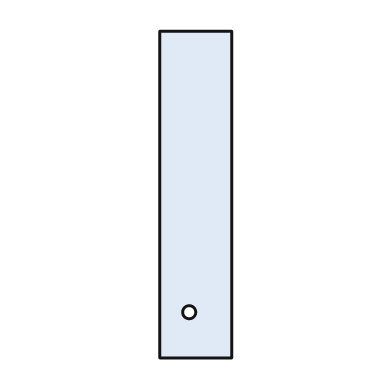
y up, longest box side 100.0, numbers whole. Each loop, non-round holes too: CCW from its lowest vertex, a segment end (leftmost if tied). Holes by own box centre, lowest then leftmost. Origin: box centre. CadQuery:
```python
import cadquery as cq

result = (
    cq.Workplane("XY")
    .moveTo(-11.0, -50.0)
    .lineTo(11.0, -50.0)
    .lineTo(11.0, 50.0)
    .lineTo(-11.0, 50.0)
    .close()
    .moveTo(-2.0, -36.0)
    .circle(2.0)
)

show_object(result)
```